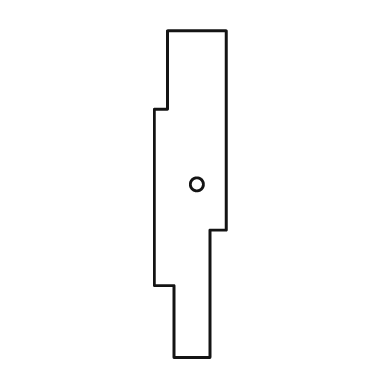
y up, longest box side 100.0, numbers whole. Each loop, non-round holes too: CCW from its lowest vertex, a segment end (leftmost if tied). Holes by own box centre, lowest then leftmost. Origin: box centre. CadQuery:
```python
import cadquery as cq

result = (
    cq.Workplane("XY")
    .moveTo(-5.0, -50.0)
    .lineTo(6.0, -50.0)
    .lineTo(6.0, -11.0)
    .lineTo(11.0, -11.0)
    .lineTo(11.0, 50.0)
    .lineTo(-7.0, 50.0)
    .lineTo(-7.0, 26.0)
    .lineTo(-11.0, 26.0)
    .lineTo(-11.0, -28.0)
    .lineTo(-5.0, -28.0)
    .close()
    .moveTo(2.0, 3.0)
    .circle(2.0)
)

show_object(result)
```